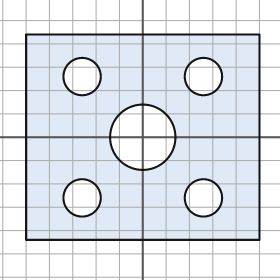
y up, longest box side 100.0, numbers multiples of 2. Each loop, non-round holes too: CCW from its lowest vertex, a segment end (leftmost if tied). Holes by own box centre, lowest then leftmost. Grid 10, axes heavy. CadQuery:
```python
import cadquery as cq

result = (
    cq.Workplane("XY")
    .moveTo(-50.0, -44.0)
    .lineTo(50.0, -44.0)
    .lineTo(50.0, 44.0)
    .lineTo(-50.0, 44.0)
    .close()
    .moveTo(-26.0, -26.0)
    .circle(8.0)
    .moveTo(26.0, -26.0)
    .circle(8.0)
    .moveTo(0.0, 0.0)
    .circle(14.0)
    .moveTo(-26.0, 26.0)
    .circle(8.0)
    .moveTo(26.0, 26.0)
    .circle(8.0)
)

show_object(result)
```